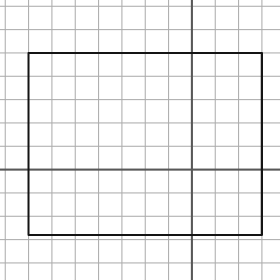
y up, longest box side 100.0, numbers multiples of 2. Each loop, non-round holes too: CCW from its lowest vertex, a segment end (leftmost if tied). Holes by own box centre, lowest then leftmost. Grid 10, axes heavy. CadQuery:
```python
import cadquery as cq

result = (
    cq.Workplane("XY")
    .moveTo(-70.0, -28.0)
    .lineTo(30.0, -28.0)
    .lineTo(30.0, 50.0)
    .lineTo(-70.0, 50.0)
    .close()
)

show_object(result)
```